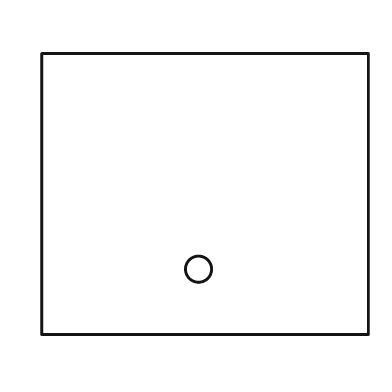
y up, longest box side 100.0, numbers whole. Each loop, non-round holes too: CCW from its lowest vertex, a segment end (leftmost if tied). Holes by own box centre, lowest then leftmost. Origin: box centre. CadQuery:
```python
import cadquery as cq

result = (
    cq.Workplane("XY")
    .moveTo(-50.0, -43.0)
    .lineTo(50.0, -43.0)
    .lineTo(50.0, 43.0)
    .lineTo(-50.0, 43.0)
    .close()
    .moveTo(-2.0, -23.0)
    .circle(4.0)
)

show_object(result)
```